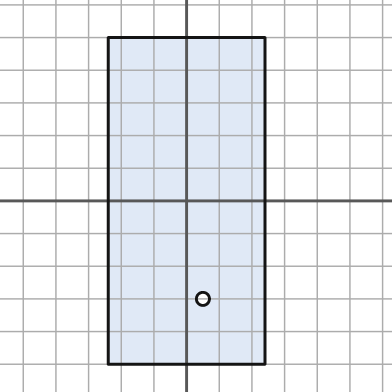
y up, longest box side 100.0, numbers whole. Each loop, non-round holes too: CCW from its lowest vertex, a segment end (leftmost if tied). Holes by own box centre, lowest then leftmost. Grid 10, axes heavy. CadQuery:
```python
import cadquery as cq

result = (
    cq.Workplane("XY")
    .moveTo(-24.0, -50.0)
    .lineTo(24.0, -50.0)
    .lineTo(24.0, 50.0)
    .lineTo(-24.0, 50.0)
    .close()
    .moveTo(5.0, -30.0)
    .circle(2.0)
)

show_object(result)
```